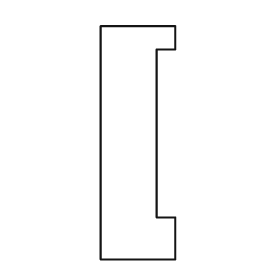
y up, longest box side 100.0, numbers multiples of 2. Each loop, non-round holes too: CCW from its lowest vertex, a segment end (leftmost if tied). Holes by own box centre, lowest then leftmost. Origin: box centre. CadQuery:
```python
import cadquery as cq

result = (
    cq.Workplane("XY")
    .moveTo(-16.0, -50.0)
    .lineTo(16.0, -50.0)
    .lineTo(16.0, -32.0)
    .lineTo(8.0, -32.0)
    .lineTo(8.0, 40.0)
    .lineTo(16.0, 40.0)
    .lineTo(16.0, 50.0)
    .lineTo(-16.0, 50.0)
    .close()
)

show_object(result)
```